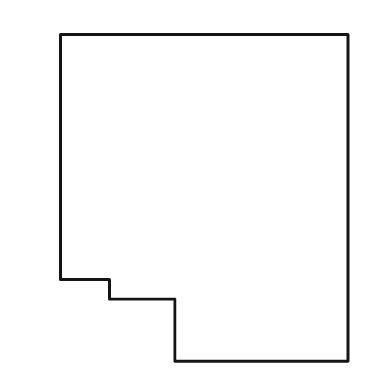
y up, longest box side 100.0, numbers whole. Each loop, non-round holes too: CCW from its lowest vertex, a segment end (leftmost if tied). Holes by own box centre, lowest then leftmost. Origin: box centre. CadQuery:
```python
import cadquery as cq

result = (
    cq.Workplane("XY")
    .moveTo(-9.0, -50.0)
    .lineTo(44.0, -50.0)
    .lineTo(44.0, 50.0)
    .lineTo(-44.0, 50.0)
    .lineTo(-44.0, -25.0)
    .lineTo(-29.0, -25.0)
    .lineTo(-29.0, -31.0)
    .lineTo(-9.0, -31.0)
    .close()
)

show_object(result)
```